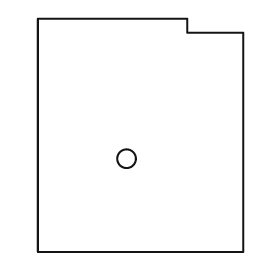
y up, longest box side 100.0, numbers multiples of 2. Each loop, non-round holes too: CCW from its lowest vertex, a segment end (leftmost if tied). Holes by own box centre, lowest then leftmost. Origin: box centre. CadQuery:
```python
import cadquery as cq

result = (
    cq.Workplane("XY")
    .moveTo(-44.0, -50.0)
    .lineTo(44.0, -50.0)
    .lineTo(44.0, 44.0)
    .lineTo(20.0, 44.0)
    .lineTo(20.0, 50.0)
    .lineTo(-44.0, 50.0)
    .close()
    .moveTo(-6.0, -10.0)
    .circle(4.0)
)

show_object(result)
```